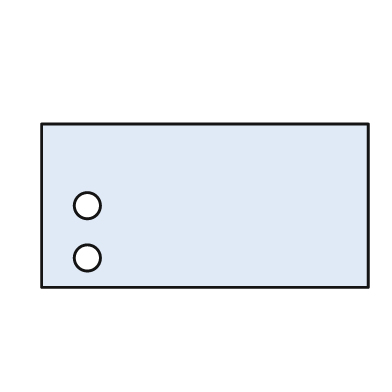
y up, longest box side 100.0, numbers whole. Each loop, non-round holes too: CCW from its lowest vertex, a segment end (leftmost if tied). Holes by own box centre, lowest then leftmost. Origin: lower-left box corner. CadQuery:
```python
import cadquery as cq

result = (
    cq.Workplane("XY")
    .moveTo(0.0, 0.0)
    .lineTo(100.0, 0.0)
    .lineTo(100.0, 50.0)
    .lineTo(0.0, 50.0)
    .close()
    .moveTo(14.0, 9.0)
    .circle(4.0)
    .moveTo(14.0, 25.0)
    .circle(4.0)
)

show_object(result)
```